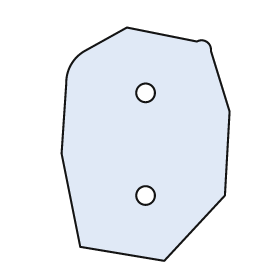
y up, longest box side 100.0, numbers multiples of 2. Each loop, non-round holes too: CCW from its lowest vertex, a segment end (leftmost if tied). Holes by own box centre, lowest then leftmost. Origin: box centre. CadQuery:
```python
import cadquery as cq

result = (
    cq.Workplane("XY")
    .moveTo(8.0, -50.0)
    .lineTo(34.0, -22.0)
    .lineTo(36.0, 14.0)
    .lineTo(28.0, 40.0)
    .threePointArc((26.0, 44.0), (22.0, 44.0))
    .lineTo(-8.0, 50.0)
    .lineTo(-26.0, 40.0)
    .threePointArc((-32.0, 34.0), (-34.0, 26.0))
    .lineTo(-36.0, -4.0)
    .lineTo(-28.0, -44.0)
    .close()
    .moveTo(0.0, -22.0)
    .circle(4.0)
    .moveTo(0.0, 22.0)
    .circle(4.0)
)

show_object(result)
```